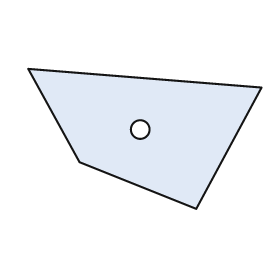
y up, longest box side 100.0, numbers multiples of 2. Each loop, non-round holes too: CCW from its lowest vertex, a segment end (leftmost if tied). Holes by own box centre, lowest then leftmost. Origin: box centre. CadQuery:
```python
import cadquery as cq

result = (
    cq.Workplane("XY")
    .moveTo(22.0, -30.0)
    .lineTo(50.0, 22.0)
    .lineTo(-50.0, 30.0)
    .lineTo(-28.0, -10.0)
    .close()
    .moveTo(-2.0, 4.0)
    .circle(4.0)
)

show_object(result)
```